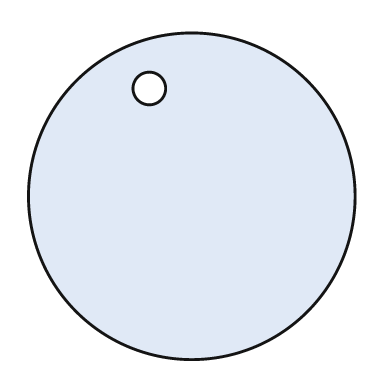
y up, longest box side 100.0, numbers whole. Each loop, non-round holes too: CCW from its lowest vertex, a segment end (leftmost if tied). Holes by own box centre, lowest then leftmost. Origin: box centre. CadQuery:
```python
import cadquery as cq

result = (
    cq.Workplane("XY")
    .moveTo(0.0, 0.0)
    .circle(50.0)
    .moveTo(-13.0, 33.0)
    .circle(5.0)
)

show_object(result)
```